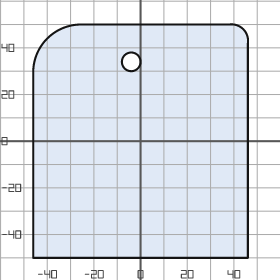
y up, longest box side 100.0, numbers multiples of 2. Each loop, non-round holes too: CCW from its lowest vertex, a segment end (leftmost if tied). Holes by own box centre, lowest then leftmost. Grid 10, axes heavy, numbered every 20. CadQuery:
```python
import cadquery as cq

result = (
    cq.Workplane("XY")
    .moveTo(-46.0, -50.0)
    .lineTo(46.0, -50.0)
    .lineTo(46.0, 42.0)
    .threePointArc((44.0, 48.0), (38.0, 50.0))
    .lineTo(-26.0, 50.0)
    .threePointArc((-40.0, 44.0), (-46.0, 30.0))
    .close()
    .moveTo(-4.0, 34.0)
    .circle(4.0)
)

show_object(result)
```